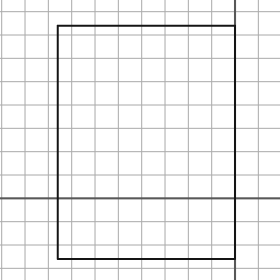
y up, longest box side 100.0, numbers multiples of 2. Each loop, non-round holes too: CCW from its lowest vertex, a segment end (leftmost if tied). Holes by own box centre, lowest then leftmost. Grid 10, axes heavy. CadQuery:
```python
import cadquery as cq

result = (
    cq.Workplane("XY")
    .moveTo(-76.0, -26.0)
    .lineTo(0.0, -26.0)
    .lineTo(0.0, 74.0)
    .lineTo(-76.0, 74.0)
    .close()
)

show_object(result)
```